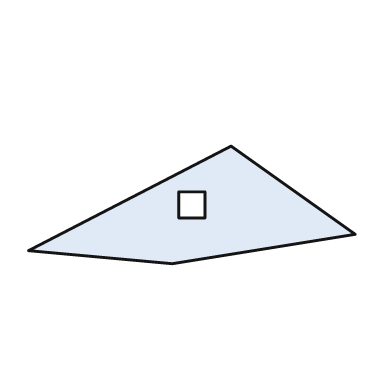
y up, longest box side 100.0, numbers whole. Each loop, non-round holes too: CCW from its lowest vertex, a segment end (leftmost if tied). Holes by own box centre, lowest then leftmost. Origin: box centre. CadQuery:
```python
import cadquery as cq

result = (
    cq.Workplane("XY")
    .moveTo(-6.0, -18.0)
    .lineTo(50.0, -9.0)
    .lineTo(12.0, 18.0)
    .lineTo(-50.0, -14.0)
    .close()
    .moveTo(-4.0, -4.0)
    .lineTo(4.0, -4.0)
    .lineTo(4.0, 4.0)
    .lineTo(-4.0, 4.0)
    .close()
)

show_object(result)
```